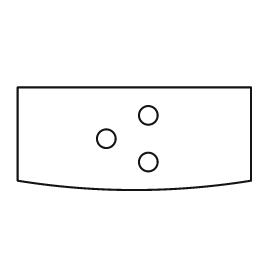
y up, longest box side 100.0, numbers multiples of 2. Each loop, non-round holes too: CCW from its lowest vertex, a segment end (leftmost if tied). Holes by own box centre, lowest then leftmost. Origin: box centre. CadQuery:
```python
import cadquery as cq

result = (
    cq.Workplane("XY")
    .moveTo(-50.0, -18.0)
    .threePointArc((0.0, -22.0), (50.0, -18.0))
    .lineTo(50.0, 22.0)
    .lineTo(-50.0, 22.0)
    .close()
    .moveTo(6.0, -10.0)
    .circle(4.0)
    .moveTo(-12.0, 0.0)
    .circle(4.0)
    .moveTo(6.0, 10.0)
    .circle(4.0)
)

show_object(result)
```